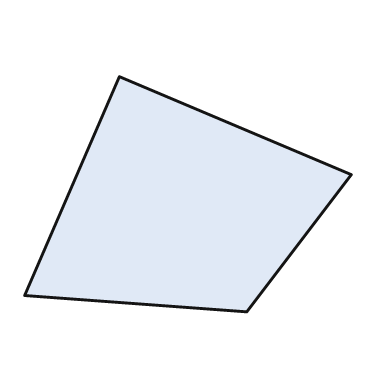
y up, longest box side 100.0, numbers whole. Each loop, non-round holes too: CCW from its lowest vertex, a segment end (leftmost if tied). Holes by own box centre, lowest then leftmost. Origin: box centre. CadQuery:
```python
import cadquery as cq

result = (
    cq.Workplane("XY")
    .moveTo(18.0, -36.0)
    .lineTo(50.0, 6.0)
    .lineTo(-21.0, 36.0)
    .lineTo(-50.0, -31.0)
    .close()
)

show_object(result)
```